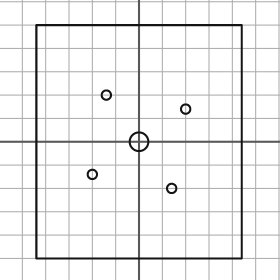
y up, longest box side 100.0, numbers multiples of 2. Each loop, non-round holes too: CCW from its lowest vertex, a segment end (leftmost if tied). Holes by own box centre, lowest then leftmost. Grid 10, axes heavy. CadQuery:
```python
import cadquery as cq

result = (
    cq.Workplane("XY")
    .moveTo(-44.0, -50.0)
    .lineTo(44.0, -50.0)
    .lineTo(44.0, 50.0)
    .lineTo(-44.0, 50.0)
    .close()
    .moveTo(14.0, -20.0)
    .circle(2.0)
    .moveTo(-20.0, -14.0)
    .circle(2.0)
    .moveTo(0.0, 0.0)
    .circle(4.0)
    .moveTo(20.0, 14.0)
    .circle(2.0)
    .moveTo(-14.0, 20.0)
    .circle(2.0)
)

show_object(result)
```